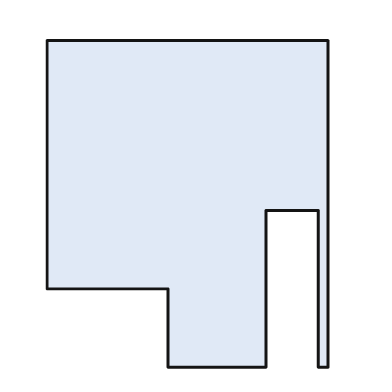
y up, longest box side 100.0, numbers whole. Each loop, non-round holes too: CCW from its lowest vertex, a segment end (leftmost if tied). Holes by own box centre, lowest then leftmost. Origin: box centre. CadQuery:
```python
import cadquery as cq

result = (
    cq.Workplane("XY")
    .moveTo(-6.0, -50.0)
    .lineTo(24.0, -50.0)
    .lineTo(24.0, -2.0)
    .lineTo(40.0, -2.0)
    .lineTo(40.0, -50.0)
    .lineTo(43.0, -50.0)
    .lineTo(43.0, 50.0)
    .lineTo(-43.0, 50.0)
    .lineTo(-43.0, -26.0)
    .lineTo(-6.0, -26.0)
    .close()
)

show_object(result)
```